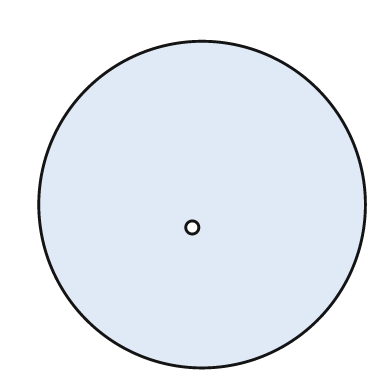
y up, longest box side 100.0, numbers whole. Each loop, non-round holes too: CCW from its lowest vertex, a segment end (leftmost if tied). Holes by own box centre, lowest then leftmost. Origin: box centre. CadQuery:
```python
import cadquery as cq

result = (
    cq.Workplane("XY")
    .moveTo(0.0, 0.0)
    .circle(50.0)
    .moveTo(-3.0, -7.0)
    .circle(2.0)
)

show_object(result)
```